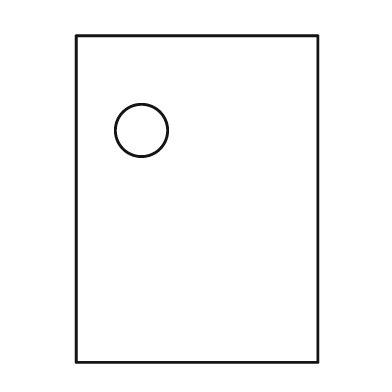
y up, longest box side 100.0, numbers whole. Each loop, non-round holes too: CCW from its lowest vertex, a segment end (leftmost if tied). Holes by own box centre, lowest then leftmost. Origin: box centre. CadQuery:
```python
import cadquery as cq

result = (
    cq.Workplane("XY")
    .moveTo(-37.0, -50.0)
    .lineTo(37.0, -50.0)
    .lineTo(37.0, 50.0)
    .lineTo(-37.0, 50.0)
    .close()
    .moveTo(-17.0, 21.0)
    .circle(8.0)
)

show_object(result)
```